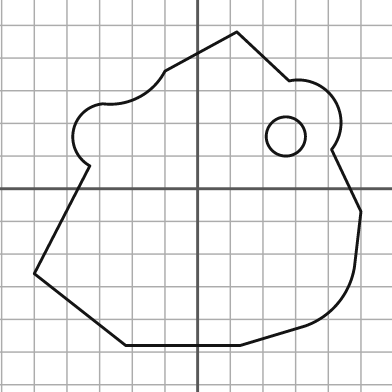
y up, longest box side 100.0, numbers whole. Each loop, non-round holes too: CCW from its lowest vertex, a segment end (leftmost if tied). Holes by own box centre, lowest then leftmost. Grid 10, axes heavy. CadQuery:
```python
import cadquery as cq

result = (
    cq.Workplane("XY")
    .moveTo(-22.0, -48.0)
    .lineTo(13.0, -48.0)
    .lineTo(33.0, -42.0)
    .threePointArc((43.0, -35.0), (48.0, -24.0))
    .lineTo(50.0, -7.0)
    .lineTo(41.0, 12.0)
    .threePointArc((42.0, 27.0), (28.0, 33.0))
    .lineTo(12.0, 48.0)
    .lineTo(-10.0, 36.0)
    .threePointArc((-18.0, 28.0), (-29.0, 26.0))
    .threePointArc((-38.0, 18.0), (-33.0, 7.0))
    .lineTo(-50.0, -26.0)
    .close()
    .moveTo(27.0, 16.0)
    .circle(6.0)
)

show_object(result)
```